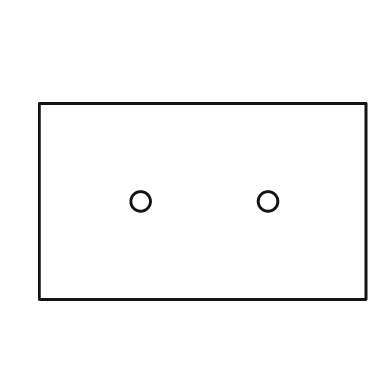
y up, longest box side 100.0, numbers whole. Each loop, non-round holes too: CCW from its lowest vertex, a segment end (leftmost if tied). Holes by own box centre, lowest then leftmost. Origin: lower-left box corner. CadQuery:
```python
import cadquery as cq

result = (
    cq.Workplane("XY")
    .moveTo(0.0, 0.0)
    .lineTo(100.0, 0.0)
    .lineTo(100.0, 60.0)
    .lineTo(0.0, 60.0)
    .close()
    .moveTo(31.0, 30.0)
    .circle(3.0)
    .moveTo(70.0, 30.0)
    .circle(3.0)
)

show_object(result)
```